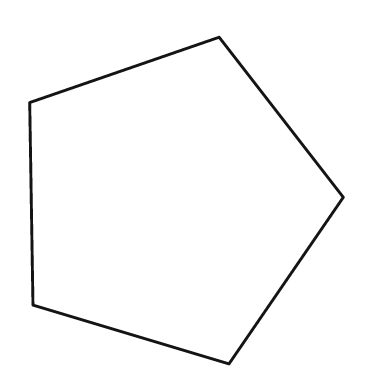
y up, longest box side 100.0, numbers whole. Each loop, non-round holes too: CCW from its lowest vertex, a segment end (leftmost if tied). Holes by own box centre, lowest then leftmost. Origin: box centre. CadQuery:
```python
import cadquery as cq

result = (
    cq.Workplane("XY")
    .moveTo(13.0, -50.0)
    .lineTo(48.0, 1.0)
    .lineTo(10.0, 50.0)
    .lineTo(-48.0, 30.0)
    .lineTo(-47.0, -32.0)
    .close()
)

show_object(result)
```